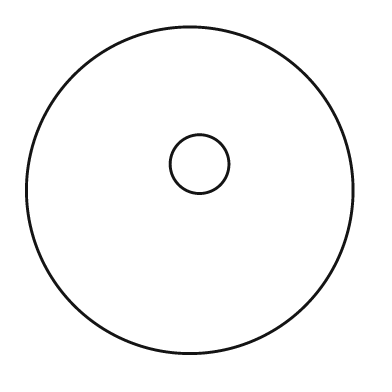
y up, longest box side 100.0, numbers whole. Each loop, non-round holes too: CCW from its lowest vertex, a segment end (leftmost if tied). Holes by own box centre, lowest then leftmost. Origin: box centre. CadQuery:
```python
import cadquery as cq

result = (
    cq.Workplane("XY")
    .moveTo(0.0, 0.0)
    .circle(50.0)
    .moveTo(3.0, 8.0)
    .circle(9.0)
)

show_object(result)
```